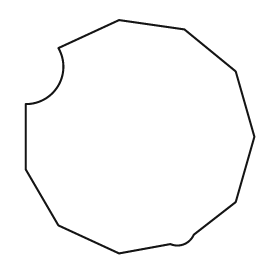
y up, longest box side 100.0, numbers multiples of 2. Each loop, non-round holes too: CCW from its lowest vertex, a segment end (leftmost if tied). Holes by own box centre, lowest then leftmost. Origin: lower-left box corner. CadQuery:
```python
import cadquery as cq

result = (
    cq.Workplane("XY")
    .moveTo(40.0, 0.0)
    .lineTo(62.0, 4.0)
    .threePointArc((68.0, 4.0), (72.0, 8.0))
    .lineTo(90.0, 22.0)
    .lineTo(98.0, 50.0)
    .lineTo(90.0, 78.0)
    .lineTo(68.0, 96.0)
    .lineTo(40.0, 100.0)
    .lineTo(14.0, 88.0)
    .threePointArc((14.0, 72.0), (0.0, 64.0))
    .lineTo(0.0, 36.0)
    .lineTo(14.0, 12.0)
    .close()
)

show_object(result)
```